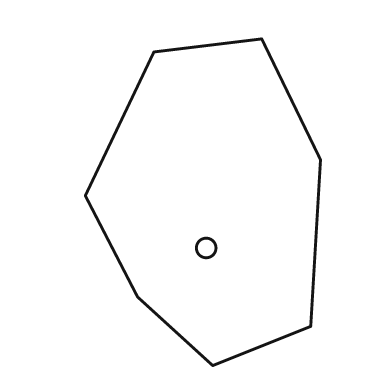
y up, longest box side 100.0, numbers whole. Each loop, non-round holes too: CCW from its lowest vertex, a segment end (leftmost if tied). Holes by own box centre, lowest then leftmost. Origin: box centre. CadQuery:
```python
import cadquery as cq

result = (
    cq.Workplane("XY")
    .moveTo(3.0, -50.0)
    .lineTo(33.0, -38.0)
    .lineTo(36.0, 13.0)
    .lineTo(18.0, 50.0)
    .lineTo(-15.0, 46.0)
    .lineTo(-36.0, 2.0)
    .lineTo(-20.0, -29.0)
    .close()
    .moveTo(1.0, -14.0)
    .circle(3.0)
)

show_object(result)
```